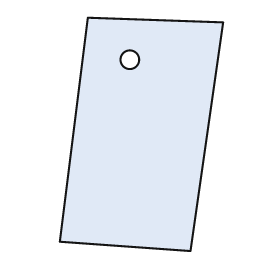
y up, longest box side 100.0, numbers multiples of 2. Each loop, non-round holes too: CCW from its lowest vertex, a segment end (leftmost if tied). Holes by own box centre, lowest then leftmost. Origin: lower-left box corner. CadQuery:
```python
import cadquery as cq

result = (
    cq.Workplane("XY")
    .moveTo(56.0, 0.0)
    .lineTo(70.0, 98.0)
    .lineTo(12.0, 100.0)
    .lineTo(0.0, 4.0)
    .close()
    .moveTo(30.0, 82.0)
    .circle(4.0)
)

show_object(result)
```